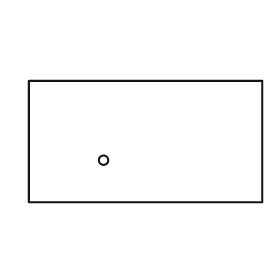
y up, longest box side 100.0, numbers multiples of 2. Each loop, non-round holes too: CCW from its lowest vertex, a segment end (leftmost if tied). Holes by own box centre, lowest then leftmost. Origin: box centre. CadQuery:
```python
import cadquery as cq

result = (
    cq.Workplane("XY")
    .moveTo(-50.0, -26.0)
    .lineTo(50.0, -26.0)
    .lineTo(50.0, 26.0)
    .lineTo(-50.0, 26.0)
    .close()
    .moveTo(-18.0, -8.0)
    .circle(2.0)
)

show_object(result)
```